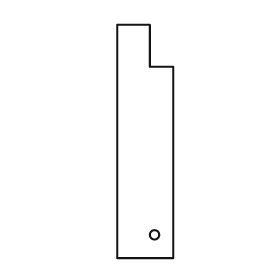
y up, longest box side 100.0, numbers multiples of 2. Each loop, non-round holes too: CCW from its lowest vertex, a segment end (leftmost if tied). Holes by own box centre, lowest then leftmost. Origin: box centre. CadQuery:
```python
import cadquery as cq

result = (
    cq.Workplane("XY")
    .moveTo(-12.0, -50.0)
    .lineTo(12.0, -50.0)
    .lineTo(12.0, 32.0)
    .lineTo(2.0, 32.0)
    .lineTo(2.0, 50.0)
    .lineTo(-12.0, 50.0)
    .close()
    .moveTo(4.0, -40.0)
    .circle(2.0)
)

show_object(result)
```